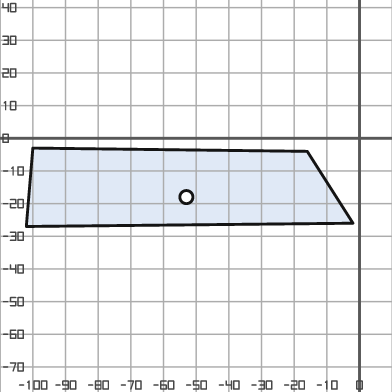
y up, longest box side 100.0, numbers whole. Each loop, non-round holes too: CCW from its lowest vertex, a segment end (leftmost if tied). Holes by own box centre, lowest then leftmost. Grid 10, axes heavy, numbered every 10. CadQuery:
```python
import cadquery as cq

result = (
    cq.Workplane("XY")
    .moveTo(-102.0, -27.0)
    .lineTo(-2.0, -26.0)
    .lineTo(-16.0, -4.0)
    .lineTo(-100.0, -3.0)
    .close()
    .moveTo(-53.0, -18.0)
    .circle(2.0)
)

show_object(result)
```